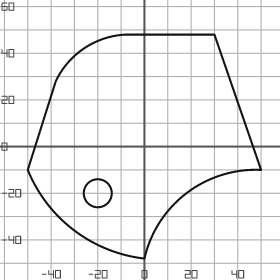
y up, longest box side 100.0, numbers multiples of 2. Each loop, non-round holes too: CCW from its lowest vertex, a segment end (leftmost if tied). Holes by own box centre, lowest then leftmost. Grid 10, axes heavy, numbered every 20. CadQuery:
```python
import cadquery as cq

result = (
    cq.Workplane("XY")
    .moveTo(0.0, -48.0)
    .threePointArc((18.0, -20.0), (50.0, -10.0))
    .lineTo(30.0, 48.0)
    .lineTo(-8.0, 48.0)
    .threePointArc((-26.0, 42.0), (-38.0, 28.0))
    .lineTo(-50.0, -10.0)
    .threePointArc((-30.0, -36.0), (0.0, -48.0))
    .close()
    .moveTo(-20.0, -20.0)
    .circle(6.0)
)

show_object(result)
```